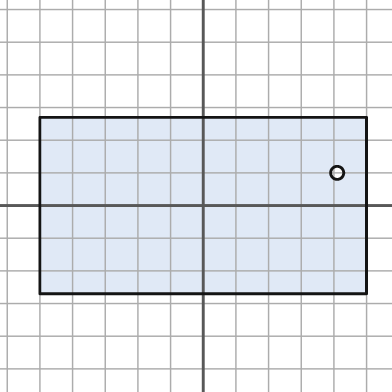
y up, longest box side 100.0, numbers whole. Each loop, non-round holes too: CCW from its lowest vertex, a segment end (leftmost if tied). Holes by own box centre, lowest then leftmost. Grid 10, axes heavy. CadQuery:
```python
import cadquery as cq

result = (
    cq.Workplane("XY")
    .moveTo(-50.0, -27.0)
    .lineTo(50.0, -27.0)
    .lineTo(50.0, 27.0)
    .lineTo(-50.0, 27.0)
    .close()
    .moveTo(41.0, 10.0)
    .circle(2.0)
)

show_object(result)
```